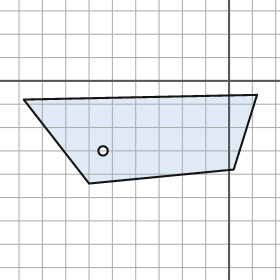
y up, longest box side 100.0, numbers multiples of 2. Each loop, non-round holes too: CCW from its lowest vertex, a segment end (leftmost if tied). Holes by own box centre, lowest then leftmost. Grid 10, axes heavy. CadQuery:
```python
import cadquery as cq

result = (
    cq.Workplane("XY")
    .moveTo(-60.0, -44.0)
    .lineTo(2.0, -38.0)
    .lineTo(12.0, -6.0)
    .lineTo(-88.0, -8.0)
    .close()
    .moveTo(-54.0, -30.0)
    .circle(2.0)
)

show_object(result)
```